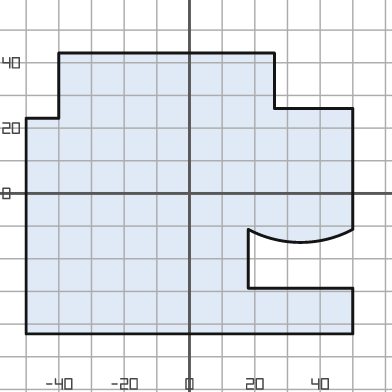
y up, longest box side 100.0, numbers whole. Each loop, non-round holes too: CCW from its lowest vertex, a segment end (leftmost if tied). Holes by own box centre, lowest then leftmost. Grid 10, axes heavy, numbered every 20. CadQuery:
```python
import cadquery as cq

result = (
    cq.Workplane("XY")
    .moveTo(-50.0, -43.0)
    .lineTo(50.0, -43.0)
    .lineTo(50.0, -29.0)
    .lineTo(18.0, -29.0)
    .lineTo(18.0, -11.0)
    .threePointArc((34.0, -15.0), (50.0, -11.0))
    .lineTo(50.0, 26.0)
    .lineTo(26.0, 26.0)
    .lineTo(26.0, 43.0)
    .lineTo(-40.0, 43.0)
    .lineTo(-40.0, 23.0)
    .lineTo(-50.0, 23.0)
    .close()
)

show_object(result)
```